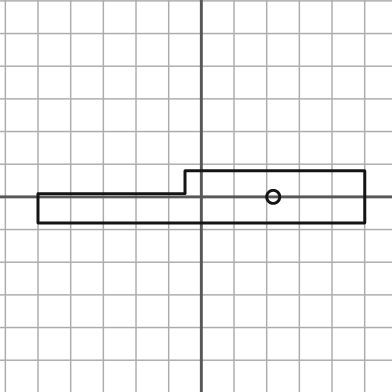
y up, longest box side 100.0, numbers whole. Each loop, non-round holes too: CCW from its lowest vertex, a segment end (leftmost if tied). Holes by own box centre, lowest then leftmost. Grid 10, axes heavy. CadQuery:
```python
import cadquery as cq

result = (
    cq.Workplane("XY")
    .moveTo(-50.0, -8.0)
    .lineTo(50.0, -8.0)
    .lineTo(50.0, 8.0)
    .lineTo(-5.0, 8.0)
    .lineTo(-5.0, 1.0)
    .lineTo(-50.0, 1.0)
    .close()
    .moveTo(22.0, 0.0)
    .circle(2.0)
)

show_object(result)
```